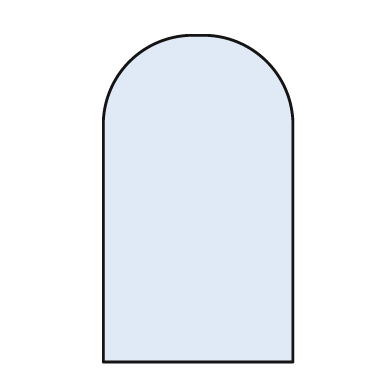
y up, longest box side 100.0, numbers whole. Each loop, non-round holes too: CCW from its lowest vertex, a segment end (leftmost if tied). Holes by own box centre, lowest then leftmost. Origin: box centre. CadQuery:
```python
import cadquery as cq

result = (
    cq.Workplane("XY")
    .moveTo(-29.0, -50.0)
    .lineTo(29.0, -50.0)
    .lineTo(29.0, 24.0)
    .threePointArc((21.0, 42.0), (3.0, 50.0))
    .lineTo(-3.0, 50.0)
    .threePointArc((-21.0, 42.0), (-29.0, 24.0))
    .close()
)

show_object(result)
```